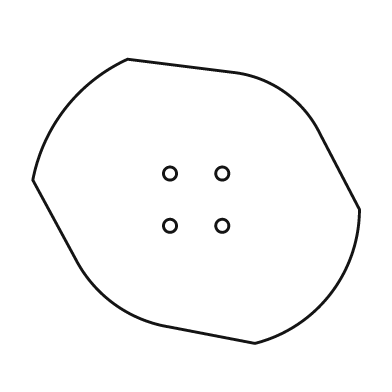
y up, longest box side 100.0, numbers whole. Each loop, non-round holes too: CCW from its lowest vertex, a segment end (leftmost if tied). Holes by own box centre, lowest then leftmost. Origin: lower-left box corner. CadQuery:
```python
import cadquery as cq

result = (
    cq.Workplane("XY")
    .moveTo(68.0, 0.0)
    .threePointArc((91.0, 15.0), (100.0, 41.0))
    .lineTo(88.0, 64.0)
    .threePointArc((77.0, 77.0), (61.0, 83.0))
    .lineTo(29.0, 87.0)
    .threePointArc((10.0, 72.0), (0.0, 50.0))
    .lineTo(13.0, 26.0)
    .threePointArc((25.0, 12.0), (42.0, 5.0))
    .close()
    .moveTo(42.0, 36.0)
    .circle(2.0)
    .moveTo(58.0, 36.0)
    .circle(2.0)
    .moveTo(42.0, 52.0)
    .circle(2.0)
    .moveTo(58.0, 52.0)
    .circle(2.0)
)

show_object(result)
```